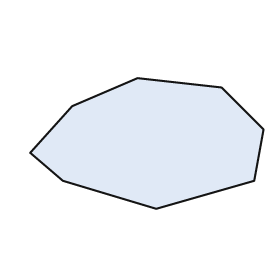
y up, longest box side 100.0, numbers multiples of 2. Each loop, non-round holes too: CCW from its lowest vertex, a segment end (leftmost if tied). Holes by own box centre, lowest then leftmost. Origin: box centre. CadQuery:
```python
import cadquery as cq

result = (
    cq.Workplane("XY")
    .moveTo(4.0, -28.0)
    .lineTo(46.0, -16.0)
    .lineTo(50.0, 6.0)
    .lineTo(32.0, 24.0)
    .lineTo(-4.0, 28.0)
    .lineTo(-32.0, 16.0)
    .lineTo(-50.0, -4.0)
    .lineTo(-36.0, -16.0)
    .close()
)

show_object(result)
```